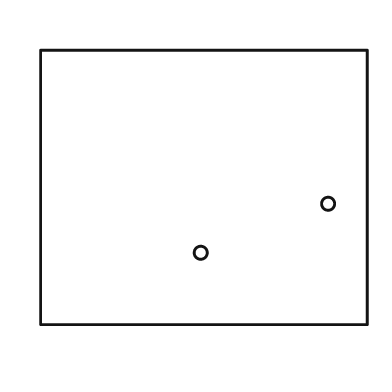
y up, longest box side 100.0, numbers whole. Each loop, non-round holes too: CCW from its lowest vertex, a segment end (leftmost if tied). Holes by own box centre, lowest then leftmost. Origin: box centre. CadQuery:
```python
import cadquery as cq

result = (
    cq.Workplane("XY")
    .moveTo(-50.0, -42.0)
    .lineTo(50.0, -42.0)
    .lineTo(50.0, 42.0)
    .lineTo(-50.0, 42.0)
    .close()
    .moveTo(-1.0, -20.0)
    .circle(2.0)
    .moveTo(38.0, -5.0)
    .circle(2.0)
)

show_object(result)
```